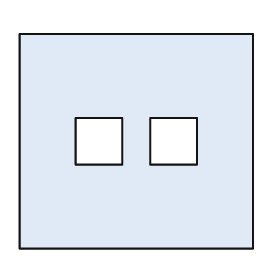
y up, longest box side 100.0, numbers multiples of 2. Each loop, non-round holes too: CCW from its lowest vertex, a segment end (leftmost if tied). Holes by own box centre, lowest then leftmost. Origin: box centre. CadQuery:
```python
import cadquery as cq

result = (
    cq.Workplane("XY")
    .moveTo(-50.0, -46.0)
    .lineTo(50.0, -46.0)
    .lineTo(50.0, 46.0)
    .lineTo(-50.0, 46.0)
    .close()
    .moveTo(-26.0, -10.0)
    .lineTo(-6.0, -10.0)
    .lineTo(-6.0, 10.0)
    .lineTo(-26.0, 10.0)
    .close()
    .moveTo(6.0, -10.0)
    .lineTo(26.0, -10.0)
    .lineTo(26.0, 10.0)
    .lineTo(6.0, 10.0)
    .close()
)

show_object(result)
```